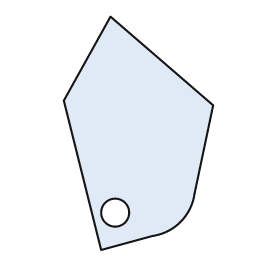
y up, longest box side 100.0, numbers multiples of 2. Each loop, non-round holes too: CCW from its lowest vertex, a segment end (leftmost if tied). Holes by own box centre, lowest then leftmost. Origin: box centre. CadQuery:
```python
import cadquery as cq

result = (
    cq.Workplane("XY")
    .moveTo(-16.0, -50.0)
    .lineTo(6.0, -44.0)
    .threePointArc((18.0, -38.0), (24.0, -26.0))
    .lineTo(32.0, 12.0)
    .lineTo(-12.0, 50.0)
    .lineTo(-32.0, 14.0)
    .close()
    .moveTo(-10.0, -34.0)
    .circle(6.0)
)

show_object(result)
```